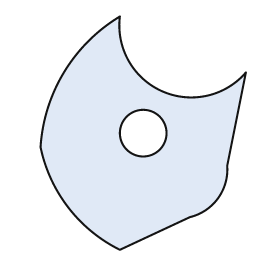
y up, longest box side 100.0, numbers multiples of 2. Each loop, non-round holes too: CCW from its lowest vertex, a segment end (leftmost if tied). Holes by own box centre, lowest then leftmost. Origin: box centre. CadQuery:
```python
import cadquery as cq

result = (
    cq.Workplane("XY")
    .moveTo(-10.0, -50.0)
    .lineTo(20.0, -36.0)
    .threePointArc((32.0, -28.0), (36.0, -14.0))
    .lineTo(44.0, 26.0)
    .threePointArc((8.0, 18.0), (-10.0, 50.0))
    .threePointArc((-34.0, 26.0), (-44.0, -6.0))
    .threePointArc((-32.0, -32.0), (-10.0, -50.0))
    .close()
    .moveTo(0.0, 0.0)
    .circle(10.0)
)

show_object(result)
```